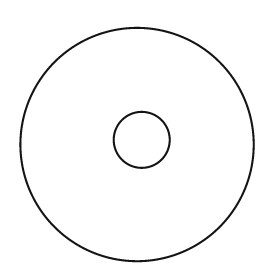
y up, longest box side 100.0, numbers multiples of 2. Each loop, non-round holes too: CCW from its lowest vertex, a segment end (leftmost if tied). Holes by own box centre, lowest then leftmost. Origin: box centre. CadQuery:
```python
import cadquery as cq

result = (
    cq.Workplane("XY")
    .moveTo(0.0, 0.0)
    .circle(50.0)
    .moveTo(2.0, 2.0)
    .circle(12.0)
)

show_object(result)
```